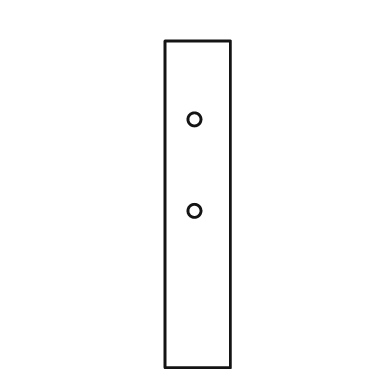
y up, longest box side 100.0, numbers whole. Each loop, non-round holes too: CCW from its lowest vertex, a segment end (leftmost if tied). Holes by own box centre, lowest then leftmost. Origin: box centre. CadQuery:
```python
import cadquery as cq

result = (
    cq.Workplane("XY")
    .moveTo(-10.0, -50.0)
    .lineTo(10.0, -50.0)
    .lineTo(10.0, 50.0)
    .lineTo(-10.0, 50.0)
    .close()
    .moveTo(-1.0, -2.0)
    .circle(2.0)
    .moveTo(-1.0, 26.0)
    .circle(2.0)
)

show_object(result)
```